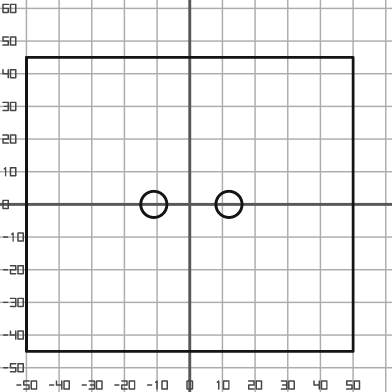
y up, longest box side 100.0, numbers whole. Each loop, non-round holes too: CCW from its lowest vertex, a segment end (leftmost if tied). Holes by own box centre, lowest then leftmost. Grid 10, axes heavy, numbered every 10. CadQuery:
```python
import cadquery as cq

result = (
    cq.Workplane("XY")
    .moveTo(-50.0, -45.0)
    .lineTo(50.0, -45.0)
    .lineTo(50.0, 45.0)
    .lineTo(-50.0, 45.0)
    .close()
    .moveTo(-11.0, 0.0)
    .circle(4.0)
    .moveTo(12.0, 0.0)
    .circle(4.0)
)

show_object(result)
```